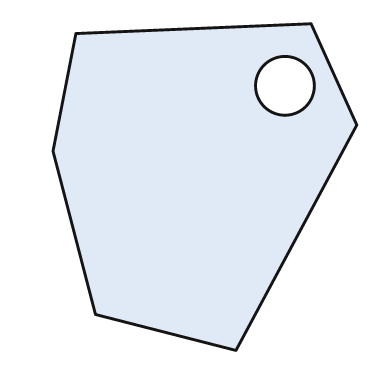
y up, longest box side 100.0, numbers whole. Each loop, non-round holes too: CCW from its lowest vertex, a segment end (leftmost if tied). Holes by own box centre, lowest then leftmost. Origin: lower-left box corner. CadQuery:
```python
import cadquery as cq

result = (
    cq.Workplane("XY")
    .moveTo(56.0, 0.0)
    .lineTo(93.0, 69.0)
    .lineTo(79.0, 100.0)
    .lineTo(7.0, 97.0)
    .lineTo(0.0, 61.0)
    .lineTo(13.0, 11.0)
    .close()
    .moveTo(71.0, 81.0)
    .circle(9.0)
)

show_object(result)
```